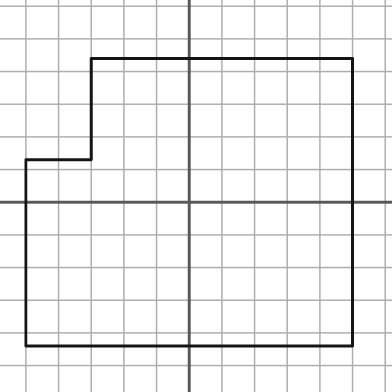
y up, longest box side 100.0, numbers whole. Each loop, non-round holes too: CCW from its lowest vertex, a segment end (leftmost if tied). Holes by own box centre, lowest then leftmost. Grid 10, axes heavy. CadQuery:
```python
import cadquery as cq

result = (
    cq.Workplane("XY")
    .moveTo(-50.0, -44.0)
    .lineTo(50.0, -44.0)
    .lineTo(50.0, 44.0)
    .lineTo(-30.0, 44.0)
    .lineTo(-30.0, 13.0)
    .lineTo(-50.0, 13.0)
    .close()
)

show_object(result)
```